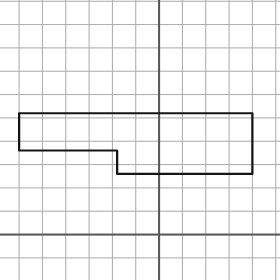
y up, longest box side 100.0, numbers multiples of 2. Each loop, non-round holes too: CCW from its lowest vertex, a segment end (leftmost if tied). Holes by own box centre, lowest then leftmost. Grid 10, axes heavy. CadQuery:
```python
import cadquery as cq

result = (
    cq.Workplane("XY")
    .moveTo(-18.0, 26.0)
    .lineTo(40.0, 26.0)
    .lineTo(40.0, 52.0)
    .lineTo(-60.0, 52.0)
    .lineTo(-60.0, 36.0)
    .lineTo(-18.0, 36.0)
    .close()
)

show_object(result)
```